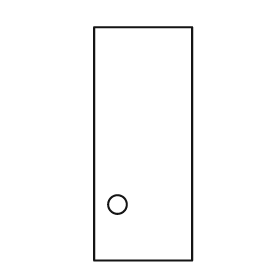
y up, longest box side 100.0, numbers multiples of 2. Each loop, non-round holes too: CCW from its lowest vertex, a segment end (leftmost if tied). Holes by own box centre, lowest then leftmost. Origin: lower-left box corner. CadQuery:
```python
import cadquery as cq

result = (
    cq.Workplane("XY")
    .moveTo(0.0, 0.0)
    .lineTo(42.0, 0.0)
    .lineTo(42.0, 100.0)
    .lineTo(0.0, 100.0)
    .close()
    .moveTo(10.0, 24.0)
    .circle(4.0)
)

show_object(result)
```